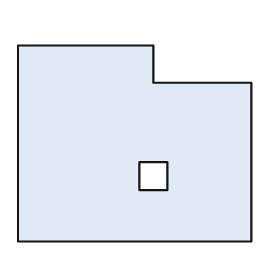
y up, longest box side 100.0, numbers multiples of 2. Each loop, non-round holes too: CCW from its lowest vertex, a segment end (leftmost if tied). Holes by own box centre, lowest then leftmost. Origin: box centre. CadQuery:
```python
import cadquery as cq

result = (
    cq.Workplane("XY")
    .moveTo(-50.0, -42.0)
    .lineTo(50.0, -42.0)
    .lineTo(50.0, 26.0)
    .lineTo(8.0, 26.0)
    .lineTo(8.0, 42.0)
    .lineTo(-50.0, 42.0)
    .close()
    .moveTo(2.0, -20.0)
    .lineTo(14.0, -20.0)
    .lineTo(14.0, -8.0)
    .lineTo(2.0, -8.0)
    .close()
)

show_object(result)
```